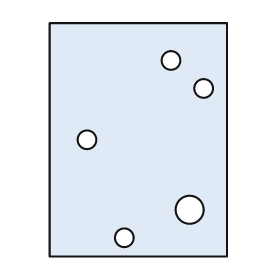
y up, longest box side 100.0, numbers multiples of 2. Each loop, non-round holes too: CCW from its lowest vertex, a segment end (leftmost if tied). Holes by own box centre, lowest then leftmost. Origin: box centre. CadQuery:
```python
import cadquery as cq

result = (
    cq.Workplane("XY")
    .moveTo(-38.0, -50.0)
    .lineTo(38.0, -50.0)
    .lineTo(38.0, 50.0)
    .lineTo(-38.0, 50.0)
    .close()
    .moveTo(-6.0, -42.0)
    .circle(4.0)
    .moveTo(22.0, -30.0)
    .circle(6.0)
    .moveTo(-22.0, 0.0)
    .circle(4.0)
    .moveTo(28.0, 22.0)
    .circle(4.0)
    .moveTo(14.0, 34.0)
    .circle(4.0)
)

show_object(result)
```